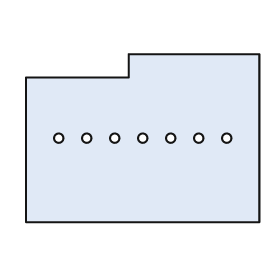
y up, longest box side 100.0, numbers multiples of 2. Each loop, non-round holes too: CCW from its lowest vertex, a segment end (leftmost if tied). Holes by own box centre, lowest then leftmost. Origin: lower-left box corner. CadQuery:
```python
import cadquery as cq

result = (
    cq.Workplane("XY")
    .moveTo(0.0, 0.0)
    .lineTo(100.0, 0.0)
    .lineTo(100.0, 72.0)
    .lineTo(44.0, 72.0)
    .lineTo(44.0, 62.0)
    .lineTo(0.0, 62.0)
    .close()
    .moveTo(14.0, 36.0)
    .circle(2.0)
    .moveTo(26.0, 36.0)
    .circle(2.0)
    .moveTo(38.0, 36.0)
    .circle(2.0)
    .moveTo(50.0, 36.0)
    .circle(2.0)
    .moveTo(62.0, 36.0)
    .circle(2.0)
    .moveTo(74.0, 36.0)
    .circle(2.0)
    .moveTo(86.0, 36.0)
    .circle(2.0)
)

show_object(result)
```